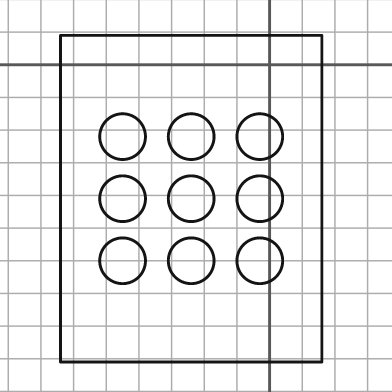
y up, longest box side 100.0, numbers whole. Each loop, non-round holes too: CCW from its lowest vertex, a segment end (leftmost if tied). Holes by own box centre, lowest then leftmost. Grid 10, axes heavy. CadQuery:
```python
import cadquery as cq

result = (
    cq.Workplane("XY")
    .moveTo(-64.0, -91.0)
    .lineTo(16.0, -91.0)
    .lineTo(16.0, 9.0)
    .lineTo(-64.0, 9.0)
    .close()
    .moveTo(-45.0, -60.0)
    .circle(7.0)
    .moveTo(-24.0, -60.0)
    .circle(7.0)
    .moveTo(-3.0, -60.0)
    .circle(7.0)
    .moveTo(-45.0, -41.0)
    .circle(7.0)
    .moveTo(-24.0, -41.0)
    .circle(7.0)
    .moveTo(-3.0, -41.0)
    .circle(7.0)
    .moveTo(-45.0, -22.0)
    .circle(7.0)
    .moveTo(-24.0, -22.0)
    .circle(7.0)
    .moveTo(-3.0, -22.0)
    .circle(7.0)
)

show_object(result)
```